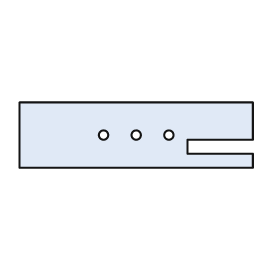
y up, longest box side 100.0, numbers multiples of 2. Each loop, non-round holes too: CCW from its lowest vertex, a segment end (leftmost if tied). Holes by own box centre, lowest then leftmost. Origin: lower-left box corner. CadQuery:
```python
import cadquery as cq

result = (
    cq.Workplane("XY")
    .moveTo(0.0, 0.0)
    .lineTo(100.0, 0.0)
    .lineTo(100.0, 6.0)
    .lineTo(72.0, 6.0)
    .lineTo(72.0, 12.0)
    .lineTo(100.0, 12.0)
    .lineTo(100.0, 28.0)
    .lineTo(0.0, 28.0)
    .close()
    .moveTo(36.0, 14.0)
    .circle(2.0)
    .moveTo(50.0, 14.0)
    .circle(2.0)
    .moveTo(64.0, 14.0)
    .circle(2.0)
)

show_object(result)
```